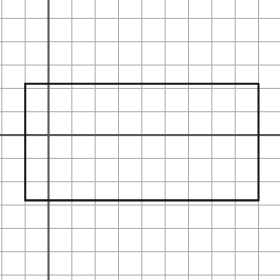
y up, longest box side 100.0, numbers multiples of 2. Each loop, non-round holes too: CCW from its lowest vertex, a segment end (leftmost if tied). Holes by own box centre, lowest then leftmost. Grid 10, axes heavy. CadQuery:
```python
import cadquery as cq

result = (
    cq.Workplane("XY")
    .moveTo(-10.0, -28.0)
    .lineTo(90.0, -28.0)
    .lineTo(90.0, 22.0)
    .lineTo(-10.0, 22.0)
    .close()
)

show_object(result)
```